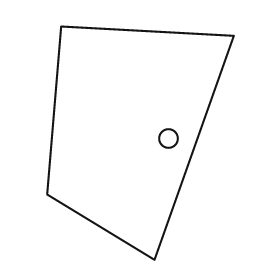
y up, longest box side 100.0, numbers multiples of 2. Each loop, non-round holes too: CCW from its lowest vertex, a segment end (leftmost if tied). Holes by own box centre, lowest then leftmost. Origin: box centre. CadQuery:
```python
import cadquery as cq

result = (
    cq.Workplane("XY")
    .moveTo(6.0, -50.0)
    .lineTo(40.0, 46.0)
    .lineTo(-34.0, 50.0)
    .lineTo(-40.0, -22.0)
    .close()
    .moveTo(12.0, 2.0)
    .circle(4.0)
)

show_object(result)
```